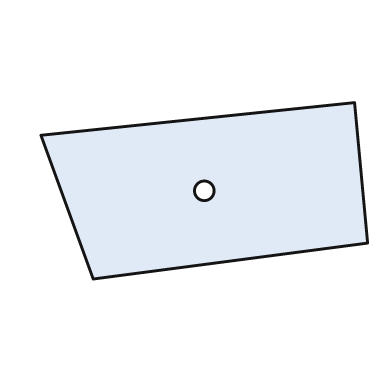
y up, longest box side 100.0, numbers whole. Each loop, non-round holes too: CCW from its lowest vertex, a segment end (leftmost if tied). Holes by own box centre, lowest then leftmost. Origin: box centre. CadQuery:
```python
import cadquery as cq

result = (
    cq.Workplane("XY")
    .moveTo(-34.0, -27.0)
    .lineTo(50.0, -16.0)
    .lineTo(46.0, 27.0)
    .lineTo(-50.0, 17.0)
    .close()
    .moveTo(0.0, 0.0)
    .circle(3.0)
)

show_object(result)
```